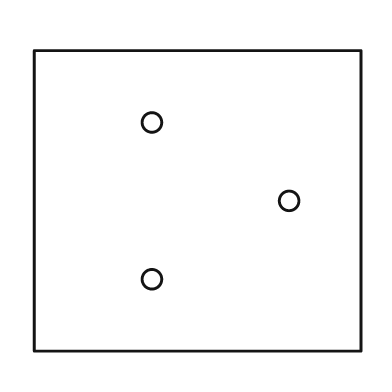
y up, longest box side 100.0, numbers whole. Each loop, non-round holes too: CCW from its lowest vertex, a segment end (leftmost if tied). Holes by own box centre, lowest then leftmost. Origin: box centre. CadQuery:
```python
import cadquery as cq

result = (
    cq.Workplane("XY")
    .moveTo(-50.0, -46.0)
    .lineTo(50.0, -46.0)
    .lineTo(50.0, 46.0)
    .lineTo(-50.0, 46.0)
    .close()
    .moveTo(-14.0, -24.0)
    .circle(3.0)
    .moveTo(28.0, 0.0)
    .circle(3.0)
    .moveTo(-14.0, 24.0)
    .circle(3.0)
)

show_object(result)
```